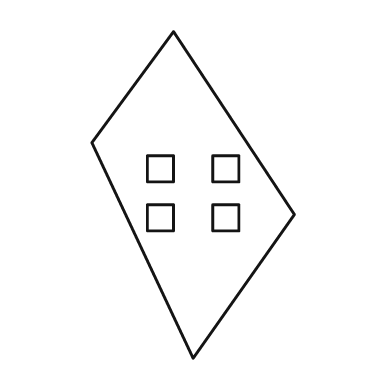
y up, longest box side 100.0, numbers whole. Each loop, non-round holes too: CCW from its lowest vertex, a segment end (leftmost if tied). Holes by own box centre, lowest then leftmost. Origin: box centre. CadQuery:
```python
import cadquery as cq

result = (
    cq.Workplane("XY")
    .moveTo(0.0, -50.0)
    .lineTo(31.0, -6.0)
    .lineTo(-6.0, 50.0)
    .lineTo(-31.0, 16.0)
    .close()
    .moveTo(-14.0, -11.0)
    .lineTo(-6.0, -11.0)
    .lineTo(-6.0, -3.0)
    .lineTo(-14.0, -3.0)
    .close()
    .moveTo(6.0, -11.0)
    .lineTo(14.0, -11.0)
    .lineTo(14.0, -3.0)
    .lineTo(6.0, -3.0)
    .close()
    .moveTo(-14.0, 4.0)
    .lineTo(-6.0, 4.0)
    .lineTo(-6.0, 12.0)
    .lineTo(-14.0, 12.0)
    .close()
    .moveTo(6.0, 4.0)
    .lineTo(14.0, 4.0)
    .lineTo(14.0, 12.0)
    .lineTo(6.0, 12.0)
    .close()
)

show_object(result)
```